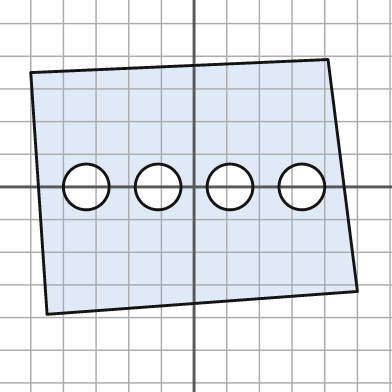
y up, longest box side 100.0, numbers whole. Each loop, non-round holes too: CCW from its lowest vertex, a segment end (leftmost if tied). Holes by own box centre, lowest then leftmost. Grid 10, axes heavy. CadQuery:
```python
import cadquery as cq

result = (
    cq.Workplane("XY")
    .moveTo(-45.0, -39.0)
    .lineTo(50.0, -32.0)
    .lineTo(41.0, 39.0)
    .lineTo(-50.0, 35.0)
    .close()
    .moveTo(-33.0, 0.0)
    .circle(7.0)
    .moveTo(-11.0, 0.0)
    .circle(7.0)
    .moveTo(11.0, 0.0)
    .circle(7.0)
    .moveTo(33.0, 0.0)
    .circle(7.0)
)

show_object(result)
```